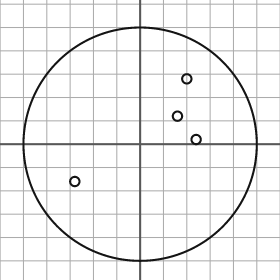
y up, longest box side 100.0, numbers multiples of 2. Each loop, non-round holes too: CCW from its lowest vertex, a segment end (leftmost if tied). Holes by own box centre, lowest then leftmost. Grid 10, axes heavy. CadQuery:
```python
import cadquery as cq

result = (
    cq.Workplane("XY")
    .moveTo(0.0, 0.0)
    .circle(50.0)
    .moveTo(-28.0, -16.0)
    .circle(2.0)
    .moveTo(24.0, 2.0)
    .circle(2.0)
    .moveTo(16.0, 12.0)
    .circle(2.0)
    .moveTo(20.0, 28.0)
    .circle(2.0)
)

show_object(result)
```